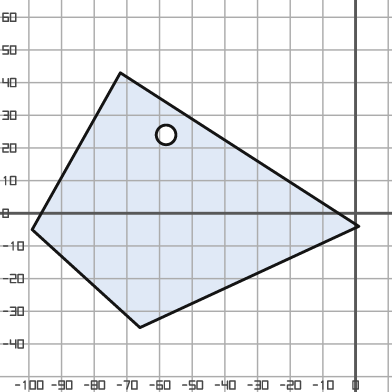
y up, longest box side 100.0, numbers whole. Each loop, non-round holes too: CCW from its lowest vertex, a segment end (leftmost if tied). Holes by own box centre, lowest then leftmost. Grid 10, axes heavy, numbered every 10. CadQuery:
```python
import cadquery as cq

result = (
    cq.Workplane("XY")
    .moveTo(-66.0, -35.0)
    .lineTo(1.0, -4.0)
    .lineTo(-72.0, 43.0)
    .lineTo(-99.0, -5.0)
    .close()
    .moveTo(-58.0, 24.0)
    .circle(3.0)
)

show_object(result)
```